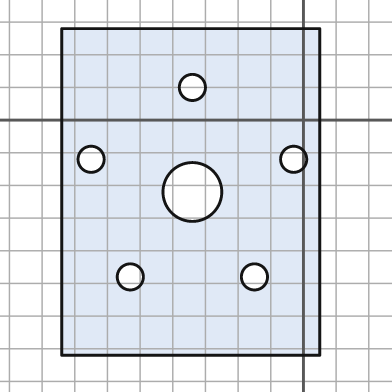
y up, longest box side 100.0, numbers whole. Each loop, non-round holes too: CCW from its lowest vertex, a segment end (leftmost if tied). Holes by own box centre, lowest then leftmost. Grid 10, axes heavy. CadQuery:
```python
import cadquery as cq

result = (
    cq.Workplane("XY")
    .moveTo(-74.0, -72.0)
    .lineTo(5.0, -72.0)
    .lineTo(5.0, 28.0)
    .lineTo(-74.0, 28.0)
    .close()
    .moveTo(-53.0, -48.0)
    .circle(4.0)
    .moveTo(-15.0, -48.0)
    .circle(4.0)
    .moveTo(-34.0, -22.0)
    .circle(9.0)
    .moveTo(-65.0, -12.0)
    .circle(4.0)
    .moveTo(-3.0, -12.0)
    .circle(4.0)
    .moveTo(-34.0, 10.0)
    .circle(4.0)
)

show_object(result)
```